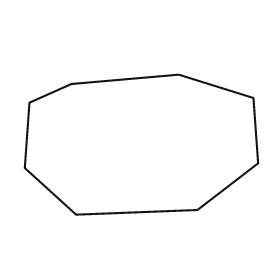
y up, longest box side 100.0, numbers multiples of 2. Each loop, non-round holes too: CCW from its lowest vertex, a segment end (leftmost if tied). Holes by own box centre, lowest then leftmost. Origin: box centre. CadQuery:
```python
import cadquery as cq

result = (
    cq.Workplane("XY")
    .moveTo(-28.0, -30.0)
    .lineTo(24.0, -28.0)
    .lineTo(50.0, -8.0)
    .lineTo(48.0, 20.0)
    .lineTo(16.0, 30.0)
    .lineTo(-30.0, 26.0)
    .lineTo(-48.0, 18.0)
    .lineTo(-50.0, -10.0)
    .close()
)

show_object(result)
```